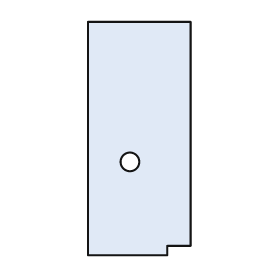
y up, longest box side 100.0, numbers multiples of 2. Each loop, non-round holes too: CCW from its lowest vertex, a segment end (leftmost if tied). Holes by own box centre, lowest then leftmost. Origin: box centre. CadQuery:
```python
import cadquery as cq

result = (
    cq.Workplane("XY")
    .moveTo(-22.0, -50.0)
    .lineTo(12.0, -50.0)
    .lineTo(12.0, -46.0)
    .lineTo(22.0, -46.0)
    .lineTo(22.0, 50.0)
    .lineTo(-22.0, 50.0)
    .close()
    .moveTo(-4.0, -10.0)
    .circle(4.0)
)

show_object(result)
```